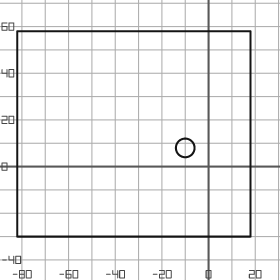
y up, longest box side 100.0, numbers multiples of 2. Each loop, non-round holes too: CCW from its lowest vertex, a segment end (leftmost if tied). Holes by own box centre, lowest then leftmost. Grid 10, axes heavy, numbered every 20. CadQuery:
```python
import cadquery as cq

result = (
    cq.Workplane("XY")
    .moveTo(-82.0, -30.0)
    .lineTo(18.0, -30.0)
    .lineTo(18.0, 58.0)
    .lineTo(-82.0, 58.0)
    .close()
    .moveTo(-10.0, 8.0)
    .circle(4.0)
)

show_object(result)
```